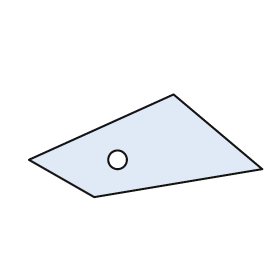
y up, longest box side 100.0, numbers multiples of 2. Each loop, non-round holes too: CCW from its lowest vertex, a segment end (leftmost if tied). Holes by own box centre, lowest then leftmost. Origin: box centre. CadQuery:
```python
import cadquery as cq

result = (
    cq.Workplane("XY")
    .moveTo(-22.0, -22.0)
    .lineTo(50.0, -10.0)
    .lineTo(12.0, 22.0)
    .lineTo(-50.0, -6.0)
    .close()
    .moveTo(-12.0, -6.0)
    .circle(4.0)
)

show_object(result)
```